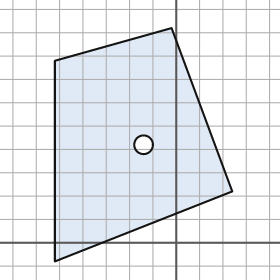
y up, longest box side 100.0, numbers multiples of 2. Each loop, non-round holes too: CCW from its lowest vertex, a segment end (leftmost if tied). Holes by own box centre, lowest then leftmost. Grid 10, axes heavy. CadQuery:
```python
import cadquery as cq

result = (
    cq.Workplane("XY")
    .moveTo(-52.0, -8.0)
    .lineTo(24.0, 22.0)
    .lineTo(-2.0, 92.0)
    .lineTo(-52.0, 78.0)
    .close()
    .moveTo(-14.0, 42.0)
    .circle(4.0)
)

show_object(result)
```